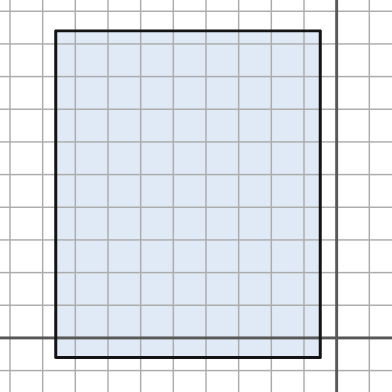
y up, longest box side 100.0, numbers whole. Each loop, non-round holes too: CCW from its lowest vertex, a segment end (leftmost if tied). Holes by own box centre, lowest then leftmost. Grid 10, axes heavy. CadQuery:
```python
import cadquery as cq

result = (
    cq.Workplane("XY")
    .moveTo(-86.0, -6.0)
    .lineTo(-5.0, -6.0)
    .lineTo(-5.0, 94.0)
    .lineTo(-86.0, 94.0)
    .close()
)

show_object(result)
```